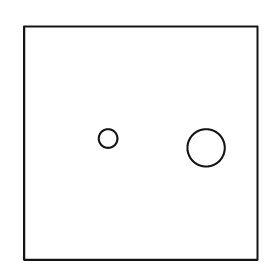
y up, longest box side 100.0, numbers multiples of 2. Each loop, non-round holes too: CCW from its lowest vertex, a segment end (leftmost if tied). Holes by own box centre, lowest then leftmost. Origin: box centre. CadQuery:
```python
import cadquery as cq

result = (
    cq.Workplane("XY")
    .moveTo(-50.0, -50.0)
    .lineTo(50.0, -50.0)
    .lineTo(50.0, 50.0)
    .lineTo(-50.0, 50.0)
    .close()
    .moveTo(28.0, -2.0)
    .circle(8.0)
    .moveTo(-14.0, 2.0)
    .circle(4.0)
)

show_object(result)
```